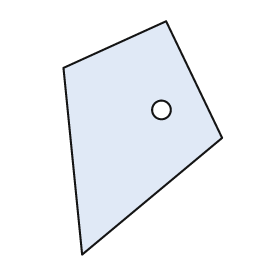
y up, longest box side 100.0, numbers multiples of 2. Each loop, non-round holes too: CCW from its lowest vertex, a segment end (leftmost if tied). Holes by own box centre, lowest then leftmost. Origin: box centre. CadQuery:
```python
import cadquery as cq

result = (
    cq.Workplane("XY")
    .moveTo(-26.0, -50.0)
    .lineTo(34.0, 0.0)
    .lineTo(10.0, 50.0)
    .lineTo(-34.0, 30.0)
    .close()
    .moveTo(8.0, 12.0)
    .circle(4.0)
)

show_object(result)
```